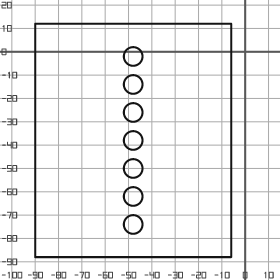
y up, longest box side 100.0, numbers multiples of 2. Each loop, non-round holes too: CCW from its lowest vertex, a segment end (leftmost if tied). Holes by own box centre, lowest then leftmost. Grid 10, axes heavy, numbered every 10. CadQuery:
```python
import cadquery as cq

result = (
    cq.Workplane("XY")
    .moveTo(-90.0, -88.0)
    .lineTo(-6.0, -88.0)
    .lineTo(-6.0, 12.0)
    .lineTo(-90.0, 12.0)
    .close()
    .moveTo(-48.0, -74.0)
    .circle(4.0)
    .moveTo(-48.0, -62.0)
    .circle(4.0)
    .moveTo(-48.0, -50.0)
    .circle(4.0)
    .moveTo(-48.0, -38.0)
    .circle(4.0)
    .moveTo(-48.0, -26.0)
    .circle(4.0)
    .moveTo(-48.0, -14.0)
    .circle(4.0)
    .moveTo(-48.0, -2.0)
    .circle(4.0)
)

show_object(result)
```